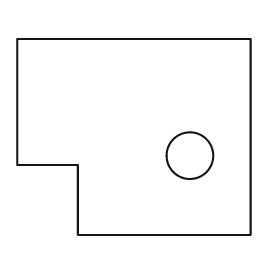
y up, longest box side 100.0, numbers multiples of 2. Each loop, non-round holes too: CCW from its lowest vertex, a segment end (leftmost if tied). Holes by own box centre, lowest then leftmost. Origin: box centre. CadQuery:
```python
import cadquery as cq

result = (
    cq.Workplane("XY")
    .moveTo(-24.0, -42.0)
    .lineTo(50.0, -42.0)
    .lineTo(50.0, 42.0)
    .lineTo(-50.0, 42.0)
    .lineTo(-50.0, -12.0)
    .lineTo(-24.0, -12.0)
    .close()
    .moveTo(24.0, -8.0)
    .circle(10.0)
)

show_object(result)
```